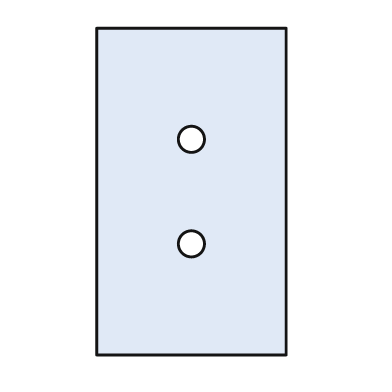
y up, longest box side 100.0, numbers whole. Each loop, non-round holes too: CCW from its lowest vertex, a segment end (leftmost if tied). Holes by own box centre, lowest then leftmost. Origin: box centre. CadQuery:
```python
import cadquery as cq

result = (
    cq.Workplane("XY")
    .moveTo(-29.0, -50.0)
    .lineTo(29.0, -50.0)
    .lineTo(29.0, 50.0)
    .lineTo(-29.0, 50.0)
    .close()
    .moveTo(0.0, -16.0)
    .circle(4.0)
    .moveTo(0.0, 16.0)
    .circle(4.0)
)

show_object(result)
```